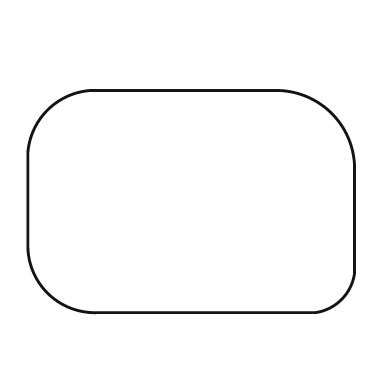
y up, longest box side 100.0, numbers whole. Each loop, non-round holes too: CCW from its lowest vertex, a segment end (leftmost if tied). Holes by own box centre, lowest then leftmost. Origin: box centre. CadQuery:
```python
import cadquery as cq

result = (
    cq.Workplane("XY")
    .moveTo(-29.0, -34.0)
    .lineTo(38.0, -34.0)
    .threePointArc((46.0, -30.0), (50.0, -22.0))
    .lineTo(50.0, 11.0)
    .threePointArc((43.0, 27.0), (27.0, 34.0))
    .lineTo(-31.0, 34.0)
    .threePointArc((-44.0, 28.0), (-50.0, 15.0))
    .lineTo(-50.0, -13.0)
    .threePointArc((-44.0, -28.0), (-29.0, -34.0))
    .close()
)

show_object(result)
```